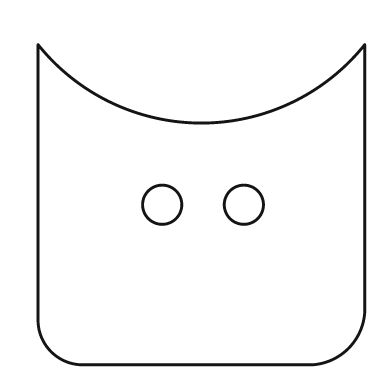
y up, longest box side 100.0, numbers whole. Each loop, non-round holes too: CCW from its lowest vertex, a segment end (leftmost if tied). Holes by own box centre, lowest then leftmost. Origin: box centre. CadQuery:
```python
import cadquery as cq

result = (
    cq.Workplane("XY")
    .moveTo(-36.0, -49.0)
    .lineTo(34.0, -49.0)
    .threePointArc((45.0, -44.0), (50.0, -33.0))
    .lineTo(50.0, 49.0)
    .threePointArc((0.0, 25.0), (-50.0, 49.0))
    .lineTo(-50.0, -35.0)
    .threePointArc((-46.0, -45.0), (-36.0, -49.0))
    .close()
    .moveTo(-12.0, 0.0)
    .circle(6.0)
    .moveTo(13.0, 0.0)
    .circle(6.0)
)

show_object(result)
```